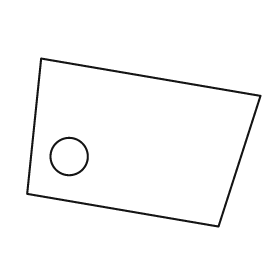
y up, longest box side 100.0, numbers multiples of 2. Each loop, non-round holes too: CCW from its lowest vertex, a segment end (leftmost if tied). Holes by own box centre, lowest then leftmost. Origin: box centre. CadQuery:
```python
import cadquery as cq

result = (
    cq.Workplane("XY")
    .moveTo(32.0, -36.0)
    .lineTo(50.0, 20.0)
    .lineTo(-44.0, 36.0)
    .lineTo(-50.0, -22.0)
    .close()
    .moveTo(-32.0, -6.0)
    .circle(8.0)
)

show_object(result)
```